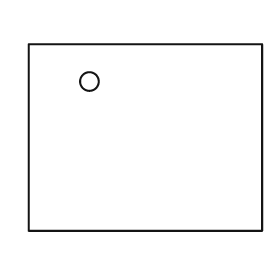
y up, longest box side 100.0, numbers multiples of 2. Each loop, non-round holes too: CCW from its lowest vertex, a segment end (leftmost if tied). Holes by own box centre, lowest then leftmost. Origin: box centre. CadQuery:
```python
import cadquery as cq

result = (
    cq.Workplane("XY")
    .moveTo(-50.0, -40.0)
    .lineTo(50.0, -40.0)
    .lineTo(50.0, 40.0)
    .lineTo(-50.0, 40.0)
    .close()
    .moveTo(-24.0, 24.0)
    .circle(4.0)
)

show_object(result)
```